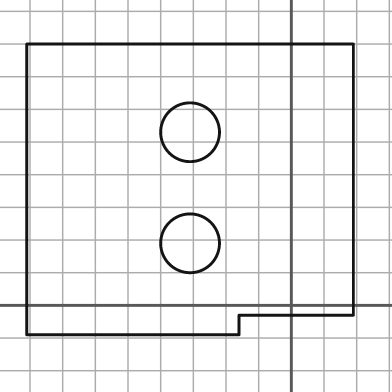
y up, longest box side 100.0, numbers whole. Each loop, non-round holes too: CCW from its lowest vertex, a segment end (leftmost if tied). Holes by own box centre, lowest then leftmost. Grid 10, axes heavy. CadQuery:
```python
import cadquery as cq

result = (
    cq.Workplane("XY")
    .moveTo(-81.0, -9.0)
    .lineTo(-16.0, -9.0)
    .lineTo(-16.0, -3.0)
    .lineTo(19.0, -3.0)
    .lineTo(19.0, 80.0)
    .lineTo(-81.0, 80.0)
    .close()
    .moveTo(-31.0, 19.0)
    .circle(9.0)
    .moveTo(-31.0, 53.0)
    .circle(9.0)
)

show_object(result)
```